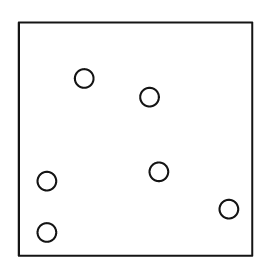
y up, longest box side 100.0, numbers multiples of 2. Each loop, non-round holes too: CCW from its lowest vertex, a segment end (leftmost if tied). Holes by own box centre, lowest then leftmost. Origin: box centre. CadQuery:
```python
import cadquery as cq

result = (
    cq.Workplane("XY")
    .moveTo(-50.0, -50.0)
    .lineTo(50.0, -50.0)
    .lineTo(50.0, 50.0)
    .lineTo(-50.0, 50.0)
    .close()
    .moveTo(-38.0, -40.0)
    .circle(4.0)
    .moveTo(40.0, -30.0)
    .circle(4.0)
    .moveTo(-38.0, -18.0)
    .circle(4.0)
    .moveTo(10.0, -14.0)
    .circle(4.0)
    .moveTo(6.0, 18.0)
    .circle(4.0)
    .moveTo(-22.0, 26.0)
    .circle(4.0)
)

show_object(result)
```